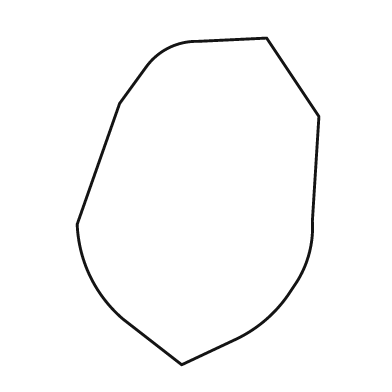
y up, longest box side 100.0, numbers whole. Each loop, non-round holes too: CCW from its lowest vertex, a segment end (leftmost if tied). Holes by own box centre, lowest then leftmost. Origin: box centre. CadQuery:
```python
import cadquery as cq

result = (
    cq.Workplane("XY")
    .moveTo(-5.0, -50.0)
    .lineTo(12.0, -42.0)
    .threePointArc((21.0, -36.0), (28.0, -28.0))
    .lineTo(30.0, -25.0)
    .threePointArc((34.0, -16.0), (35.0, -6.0))
    .lineTo(37.0, 26.0)
    .lineTo(21.0, 50.0)
    .lineTo(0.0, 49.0)
    .threePointArc((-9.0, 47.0), (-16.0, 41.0))
    .lineTo(-24.0, 30.0)
    .lineTo(-37.0, -7.0)
    .threePointArc((-33.0, -23.0), (-23.0, -36.0))
    .close()
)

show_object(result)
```